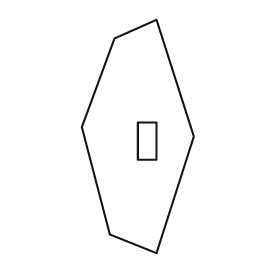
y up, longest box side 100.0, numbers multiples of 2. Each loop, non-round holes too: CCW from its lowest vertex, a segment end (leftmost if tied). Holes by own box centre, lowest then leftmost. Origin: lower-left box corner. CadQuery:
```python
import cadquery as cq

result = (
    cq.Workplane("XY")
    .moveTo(32.0, 0.0)
    .lineTo(48.0, 50.0)
    .lineTo(32.0, 100.0)
    .lineTo(14.0, 92.0)
    .lineTo(0.0, 54.0)
    .lineTo(12.0, 8.0)
    .close()
    .moveTo(24.0, 40.0)
    .lineTo(32.0, 40.0)
    .lineTo(32.0, 56.0)
    .lineTo(24.0, 56.0)
    .close()
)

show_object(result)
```